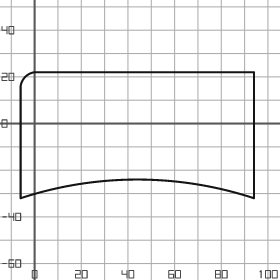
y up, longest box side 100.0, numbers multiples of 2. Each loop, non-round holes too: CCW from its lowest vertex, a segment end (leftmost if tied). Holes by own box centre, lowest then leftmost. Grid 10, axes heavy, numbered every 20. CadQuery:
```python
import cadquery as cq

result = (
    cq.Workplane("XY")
    .moveTo(-6.0, -32.0)
    .threePointArc((44.0, -24.0), (94.0, -32.0))
    .lineTo(94.0, 22.0)
    .lineTo(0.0, 22.0)
    .threePointArc((-4.0, 20.0), (-6.0, 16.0))
    .close()
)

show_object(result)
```